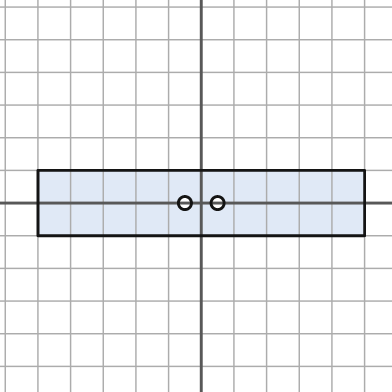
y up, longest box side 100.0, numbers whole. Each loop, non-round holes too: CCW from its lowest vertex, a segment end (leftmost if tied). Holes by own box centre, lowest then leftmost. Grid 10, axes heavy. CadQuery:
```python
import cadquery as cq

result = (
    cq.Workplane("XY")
    .moveTo(-50.0, -10.0)
    .lineTo(50.0, -10.0)
    .lineTo(50.0, 10.0)
    .lineTo(-50.0, 10.0)
    .close()
    .moveTo(-5.0, 0.0)
    .circle(2.0)
    .moveTo(5.0, 0.0)
    .circle(2.0)
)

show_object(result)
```